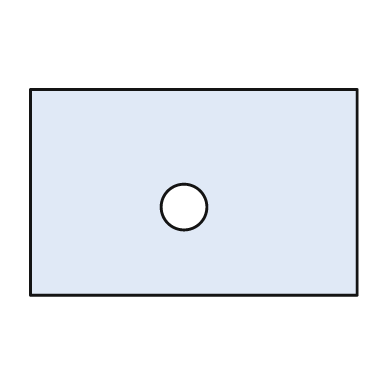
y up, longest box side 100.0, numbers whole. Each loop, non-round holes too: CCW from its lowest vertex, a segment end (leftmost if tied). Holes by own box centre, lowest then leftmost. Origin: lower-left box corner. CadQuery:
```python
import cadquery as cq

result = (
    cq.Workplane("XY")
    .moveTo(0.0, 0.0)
    .lineTo(100.0, 0.0)
    .lineTo(100.0, 63.0)
    .lineTo(0.0, 63.0)
    .close()
    .moveTo(47.0, 27.0)
    .circle(7.0)
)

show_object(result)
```